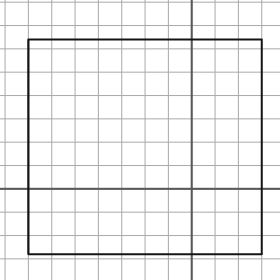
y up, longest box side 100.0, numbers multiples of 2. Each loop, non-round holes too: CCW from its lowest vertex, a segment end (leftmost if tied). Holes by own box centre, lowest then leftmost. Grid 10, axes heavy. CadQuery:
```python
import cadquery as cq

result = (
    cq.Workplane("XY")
    .moveTo(-70.0, -28.0)
    .lineTo(30.0, -28.0)
    .lineTo(30.0, 64.0)
    .lineTo(-70.0, 64.0)
    .close()
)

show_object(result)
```